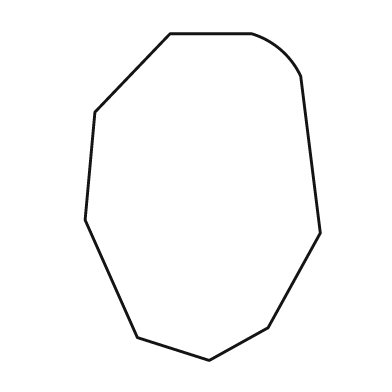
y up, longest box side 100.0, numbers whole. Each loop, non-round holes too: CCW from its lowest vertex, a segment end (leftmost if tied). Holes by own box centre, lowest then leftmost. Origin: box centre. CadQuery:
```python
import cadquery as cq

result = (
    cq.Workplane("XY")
    .moveTo(2.0, -50.0)
    .lineTo(20.0, -40.0)
    .lineTo(36.0, -11.0)
    .lineTo(30.0, 37.0)
    .threePointArc((24.0, 45.0), (15.0, 50.0))
    .lineTo(-10.0, 50.0)
    .lineTo(-33.0, 26.0)
    .lineTo(-36.0, -7.0)
    .lineTo(-20.0, -43.0)
    .close()
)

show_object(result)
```